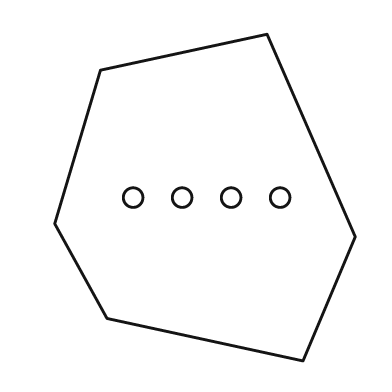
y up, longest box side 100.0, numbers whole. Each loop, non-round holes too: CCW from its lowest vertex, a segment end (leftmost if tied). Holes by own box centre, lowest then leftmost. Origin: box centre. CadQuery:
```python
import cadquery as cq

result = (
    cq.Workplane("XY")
    .moveTo(30.0, -50.0)
    .lineTo(46.0, -12.0)
    .lineTo(19.0, 50.0)
    .lineTo(-32.0, 39.0)
    .lineTo(-46.0, -8.0)
    .lineTo(-30.0, -37.0)
    .close()
    .moveTo(-22.0, 0.0)
    .circle(3.0)
    .moveTo(-7.0, 0.0)
    .circle(3.0)
    .moveTo(8.0, 0.0)
    .circle(3.0)
    .moveTo(23.0, 0.0)
    .circle(3.0)
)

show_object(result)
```